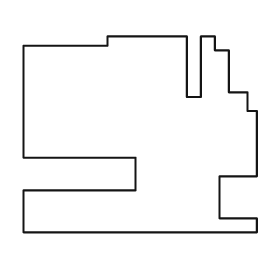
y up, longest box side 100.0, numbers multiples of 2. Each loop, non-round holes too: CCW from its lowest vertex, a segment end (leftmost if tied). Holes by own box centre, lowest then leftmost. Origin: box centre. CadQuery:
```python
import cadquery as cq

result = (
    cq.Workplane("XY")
    .moveTo(-50.0, -42.0)
    .lineTo(50.0, -42.0)
    .lineTo(50.0, -36.0)
    .lineTo(34.0, -36.0)
    .lineTo(34.0, -18.0)
    .lineTo(50.0, -18.0)
    .lineTo(50.0, 10.0)
    .lineTo(46.0, 10.0)
    .lineTo(46.0, 18.0)
    .lineTo(38.0, 18.0)
    .lineTo(38.0, 36.0)
    .lineTo(32.0, 36.0)
    .lineTo(32.0, 42.0)
    .lineTo(26.0, 42.0)
    .lineTo(26.0, 16.0)
    .lineTo(20.0, 16.0)
    .lineTo(20.0, 42.0)
    .lineTo(-14.0, 42.0)
    .lineTo(-14.0, 38.0)
    .lineTo(-50.0, 38.0)
    .lineTo(-50.0, -10.0)
    .lineTo(-2.0, -10.0)
    .lineTo(-2.0, -24.0)
    .lineTo(-50.0, -24.0)
    .close()
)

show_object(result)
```